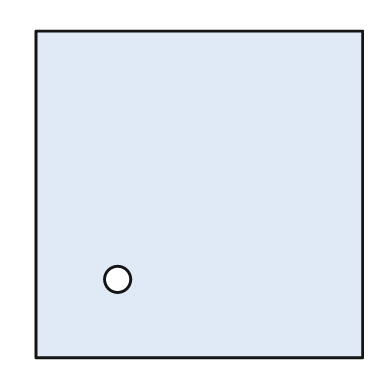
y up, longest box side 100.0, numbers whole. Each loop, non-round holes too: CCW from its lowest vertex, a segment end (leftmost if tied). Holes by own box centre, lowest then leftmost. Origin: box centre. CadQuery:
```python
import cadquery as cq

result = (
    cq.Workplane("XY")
    .moveTo(-50.0, -50.0)
    .lineTo(50.0, -50.0)
    .lineTo(50.0, 50.0)
    .lineTo(-50.0, 50.0)
    .close()
    .moveTo(-25.0, -26.0)
    .circle(4.0)
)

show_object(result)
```